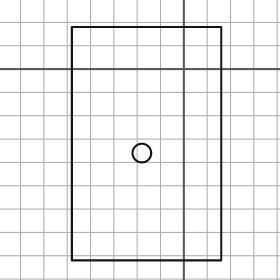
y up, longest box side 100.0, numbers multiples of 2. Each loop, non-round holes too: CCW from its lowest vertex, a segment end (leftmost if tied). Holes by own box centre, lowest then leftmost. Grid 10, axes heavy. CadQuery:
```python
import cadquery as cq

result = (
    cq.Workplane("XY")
    .moveTo(-48.0, -82.0)
    .lineTo(16.0, -82.0)
    .lineTo(16.0, 18.0)
    .lineTo(-48.0, 18.0)
    .close()
    .moveTo(-18.0, -36.0)
    .circle(4.0)
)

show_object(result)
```